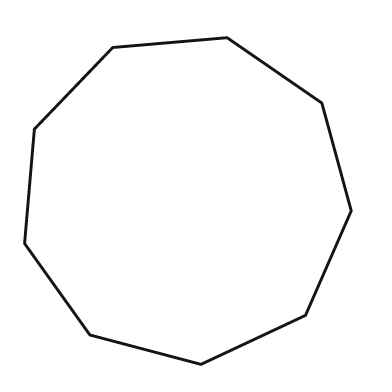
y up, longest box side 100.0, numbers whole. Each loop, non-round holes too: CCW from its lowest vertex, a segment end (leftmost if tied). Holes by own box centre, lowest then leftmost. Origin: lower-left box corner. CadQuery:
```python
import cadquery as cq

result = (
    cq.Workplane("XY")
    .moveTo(54.0, 0.0)
    .lineTo(86.0, 15.0)
    .lineTo(100.0, 47.0)
    .lineTo(91.0, 80.0)
    .lineTo(62.0, 100.0)
    .lineTo(27.0, 97.0)
    .lineTo(3.0, 72.0)
    .lineTo(0.0, 37.0)
    .lineTo(20.0, 9.0)
    .close()
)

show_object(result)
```